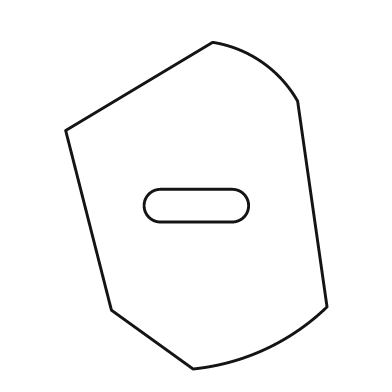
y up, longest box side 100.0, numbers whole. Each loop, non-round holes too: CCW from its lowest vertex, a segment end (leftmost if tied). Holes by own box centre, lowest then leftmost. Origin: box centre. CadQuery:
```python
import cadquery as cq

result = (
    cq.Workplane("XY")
    .moveTo(-1.0, -50.0)
    .threePointArc((21.0, -44.0), (40.0, -31.0))
    .lineTo(31.0, 32.0)
    .threePointArc((20.0, 44.0), (5.0, 50.0))
    .lineTo(-40.0, 23.0)
    .lineTo(-26.0, -32.0)
    .close()
    .moveTo(-11.0, -5.0)
    .lineTo(11.0, -5.0)
    .threePointArc((16.0, 0.0), (11.0, 5.0))
    .lineTo(-11.0, 5.0)
    .threePointArc((-16.0, 0.0), (-11.0, -5.0))
    .close()
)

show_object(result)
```